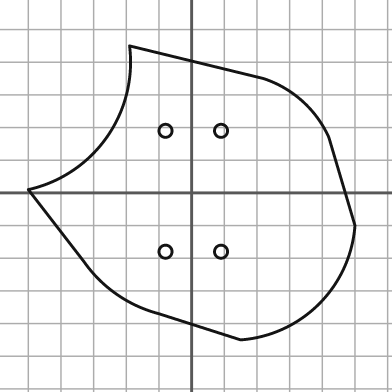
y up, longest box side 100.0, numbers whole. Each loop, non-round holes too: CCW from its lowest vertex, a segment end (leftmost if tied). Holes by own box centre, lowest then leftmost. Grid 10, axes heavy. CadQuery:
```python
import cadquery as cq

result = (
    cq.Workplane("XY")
    .moveTo(15.0, -45.0)
    .threePointArc((39.0, -34.0), (50.0, -10.0))
    .lineTo(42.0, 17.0)
    .threePointArc((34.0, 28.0), (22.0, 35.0))
    .lineTo(-19.0, 45.0)
    .threePointArc((-26.0, 17.0), (-50.0, 1.0))
    .lineTo(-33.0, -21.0)
    .threePointArc((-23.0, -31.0), (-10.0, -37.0))
    .close()
    .moveTo(-8.0, -18.0)
    .circle(2.0)
    .moveTo(9.0, -18.0)
    .circle(2.0)
    .moveTo(-8.0, 19.0)
    .circle(2.0)
    .moveTo(9.0, 19.0)
    .circle(2.0)
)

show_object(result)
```